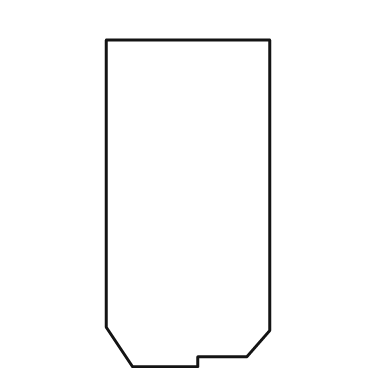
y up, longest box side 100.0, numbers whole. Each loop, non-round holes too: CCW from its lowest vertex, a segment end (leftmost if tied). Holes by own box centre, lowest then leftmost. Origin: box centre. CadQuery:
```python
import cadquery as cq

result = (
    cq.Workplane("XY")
    .moveTo(-17.0, -50.0)
    .lineTo(3.0, -50.0)
    .lineTo(3.0, -47.0)
    .lineTo(18.0, -47.0)
    .lineTo(25.0, -39.0)
    .lineTo(25.0, 50.0)
    .lineTo(-25.0, 50.0)
    .lineTo(-25.0, -38.0)
    .close()
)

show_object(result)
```